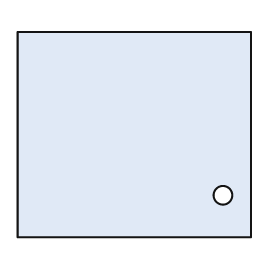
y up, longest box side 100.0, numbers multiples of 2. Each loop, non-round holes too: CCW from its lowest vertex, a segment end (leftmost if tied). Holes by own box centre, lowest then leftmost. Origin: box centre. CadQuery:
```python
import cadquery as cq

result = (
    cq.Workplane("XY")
    .moveTo(-50.0, -44.0)
    .lineTo(50.0, -44.0)
    .lineTo(50.0, 44.0)
    .lineTo(-50.0, 44.0)
    .close()
    .moveTo(38.0, -26.0)
    .circle(4.0)
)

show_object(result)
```